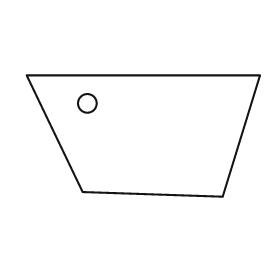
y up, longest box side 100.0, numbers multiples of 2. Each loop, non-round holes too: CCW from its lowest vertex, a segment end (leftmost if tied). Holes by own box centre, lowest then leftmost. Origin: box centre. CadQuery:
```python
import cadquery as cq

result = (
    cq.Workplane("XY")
    .moveTo(34.0, -26.0)
    .lineTo(50.0, 26.0)
    .lineTo(-50.0, 26.0)
    .lineTo(-26.0, -24.0)
    .close()
    .moveTo(-24.0, 14.0)
    .circle(4.0)
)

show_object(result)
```